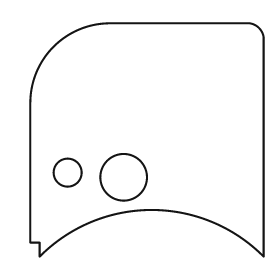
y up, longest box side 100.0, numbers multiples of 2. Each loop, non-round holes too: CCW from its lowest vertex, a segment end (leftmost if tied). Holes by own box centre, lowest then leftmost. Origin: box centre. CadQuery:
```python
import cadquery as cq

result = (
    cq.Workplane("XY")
    .moveTo(-46.0, -50.0)
    .threePointArc((2.0, -30.0), (50.0, -50.0))
    .lineTo(50.0, 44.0)
    .threePointArc((48.0, 48.0), (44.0, 50.0))
    .lineTo(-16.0, 50.0)
    .threePointArc((-40.0, 40.0), (-50.0, 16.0))
    .lineTo(-50.0, -44.0)
    .lineTo(-46.0, -44.0)
    .close()
    .moveTo(-10.0, -16.0)
    .circle(10.0)
    .moveTo(-34.0, -14.0)
    .circle(6.0)
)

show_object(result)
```